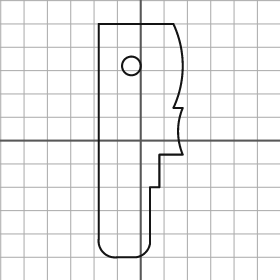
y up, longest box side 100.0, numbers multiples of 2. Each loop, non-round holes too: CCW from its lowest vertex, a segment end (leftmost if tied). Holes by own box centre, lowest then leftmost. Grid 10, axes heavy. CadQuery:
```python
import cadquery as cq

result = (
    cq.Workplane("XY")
    .moveTo(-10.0, -50.0)
    .lineTo(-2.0, -50.0)
    .threePointArc((2.0, -48.0), (4.0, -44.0))
    .lineTo(4.0, -20.0)
    .lineTo(8.0, -20.0)
    .lineTo(8.0, -6.0)
    .lineTo(18.0, -6.0)
    .threePointArc((16.0, 4.0), (18.0, 14.0))
    .lineTo(14.0, 14.0)
    .threePointArc((18.0, 32.0), (14.0, 50.0))
    .lineTo(-18.0, 50.0)
    .lineTo(-18.0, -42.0)
    .threePointArc((-16.0, -48.0), (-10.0, -50.0))
    .close()
    .moveTo(-4.0, 32.0)
    .circle(4.0)
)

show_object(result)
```